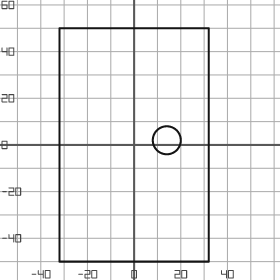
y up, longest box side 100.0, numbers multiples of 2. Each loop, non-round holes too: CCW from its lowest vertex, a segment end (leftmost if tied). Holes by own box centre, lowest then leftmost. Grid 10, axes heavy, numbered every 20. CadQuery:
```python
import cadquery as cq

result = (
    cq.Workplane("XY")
    .moveTo(-32.0, -50.0)
    .lineTo(32.0, -50.0)
    .lineTo(32.0, 50.0)
    .lineTo(-32.0, 50.0)
    .close()
    .moveTo(14.0, 2.0)
    .circle(6.0)
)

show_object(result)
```